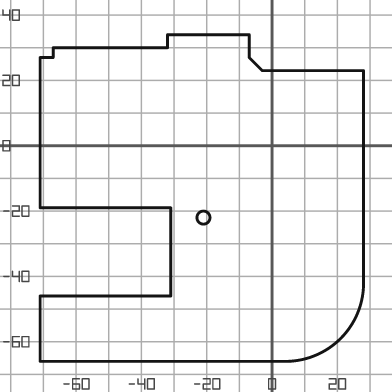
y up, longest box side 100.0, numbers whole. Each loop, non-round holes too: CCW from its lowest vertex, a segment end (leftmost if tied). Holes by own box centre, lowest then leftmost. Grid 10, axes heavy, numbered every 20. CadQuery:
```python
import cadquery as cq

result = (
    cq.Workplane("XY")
    .moveTo(-71.0, -66.0)
    .lineTo(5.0, -66.0)
    .threePointArc((21.0, -59.0), (28.0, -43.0))
    .lineTo(28.0, 23.0)
    .lineTo(-3.0, 23.0)
    .lineTo(-7.0, 27.0)
    .lineTo(-7.0, 34.0)
    .lineTo(-32.0, 34.0)
    .lineTo(-32.0, 30.0)
    .lineTo(-67.0, 30.0)
    .lineTo(-67.0, 27.0)
    .lineTo(-71.0, 27.0)
    .lineTo(-71.0, -19.0)
    .lineTo(-31.0, -19.0)
    .lineTo(-31.0, -46.0)
    .lineTo(-71.0, -46.0)
    .close()
    .moveTo(-21.0, -22.0)
    .circle(2.0)
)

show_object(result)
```